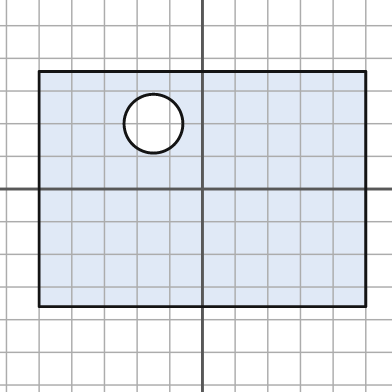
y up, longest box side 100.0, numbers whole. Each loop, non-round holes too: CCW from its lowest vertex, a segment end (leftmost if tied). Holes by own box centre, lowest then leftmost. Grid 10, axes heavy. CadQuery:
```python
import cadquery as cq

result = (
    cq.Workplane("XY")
    .moveTo(-50.0, -36.0)
    .lineTo(50.0, -36.0)
    .lineTo(50.0, 36.0)
    .lineTo(-50.0, 36.0)
    .close()
    .moveTo(-15.0, 20.0)
    .circle(9.0)
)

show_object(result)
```